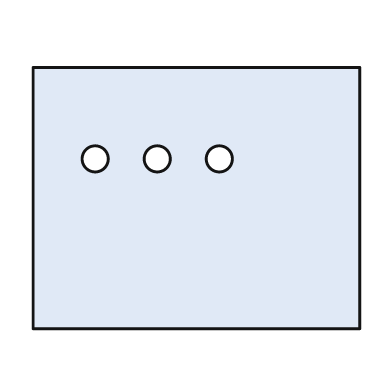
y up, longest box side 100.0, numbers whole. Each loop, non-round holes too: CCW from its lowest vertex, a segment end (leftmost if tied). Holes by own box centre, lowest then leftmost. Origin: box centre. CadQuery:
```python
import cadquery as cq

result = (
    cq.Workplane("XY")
    .moveTo(-50.0, -40.0)
    .lineTo(50.0, -40.0)
    .lineTo(50.0, 40.0)
    .lineTo(-50.0, 40.0)
    .close()
    .moveTo(-31.0, 12.0)
    .circle(4.0)
    .moveTo(-12.0, 12.0)
    .circle(4.0)
    .moveTo(7.0, 12.0)
    .circle(4.0)
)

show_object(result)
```